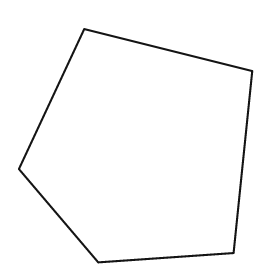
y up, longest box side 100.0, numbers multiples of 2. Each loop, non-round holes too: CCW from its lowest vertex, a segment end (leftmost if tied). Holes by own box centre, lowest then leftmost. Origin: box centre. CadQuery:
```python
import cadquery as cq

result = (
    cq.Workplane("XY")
    .moveTo(-16.0, -50.0)
    .lineTo(42.0, -46.0)
    .lineTo(50.0, 32.0)
    .lineTo(-22.0, 50.0)
    .lineTo(-50.0, -10.0)
    .close()
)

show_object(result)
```